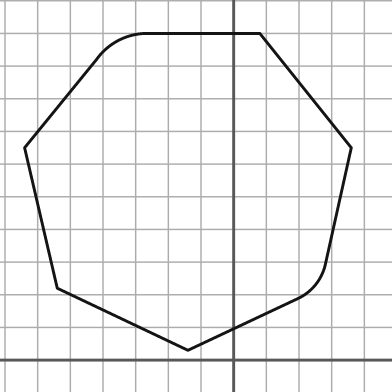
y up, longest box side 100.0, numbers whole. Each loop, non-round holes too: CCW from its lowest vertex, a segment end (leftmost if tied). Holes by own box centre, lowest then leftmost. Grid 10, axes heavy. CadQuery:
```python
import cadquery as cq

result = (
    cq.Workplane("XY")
    .moveTo(-14.0, 3.0)
    .lineTo(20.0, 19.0)
    .threePointArc((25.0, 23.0), (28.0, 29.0))
    .lineTo(36.0, 65.0)
    .lineTo(8.0, 100.0)
    .lineTo(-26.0, 100.0)
    .threePointArc((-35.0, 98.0), (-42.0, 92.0))
    .lineTo(-64.0, 65.0)
    .lineTo(-54.0, 22.0)
    .close()
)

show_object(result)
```